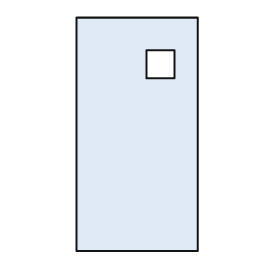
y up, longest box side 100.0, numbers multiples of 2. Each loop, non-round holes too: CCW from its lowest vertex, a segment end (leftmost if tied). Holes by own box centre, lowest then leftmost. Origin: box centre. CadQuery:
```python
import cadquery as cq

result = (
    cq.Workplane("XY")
    .moveTo(-26.0, -50.0)
    .lineTo(26.0, -50.0)
    .lineTo(26.0, 50.0)
    .lineTo(-26.0, 50.0)
    .close()
    .moveTo(4.0, 24.0)
    .lineTo(16.0, 24.0)
    .lineTo(16.0, 36.0)
    .lineTo(4.0, 36.0)
    .close()
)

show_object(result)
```